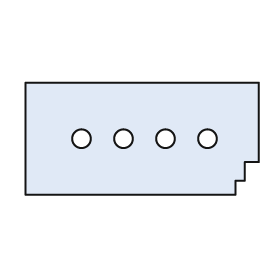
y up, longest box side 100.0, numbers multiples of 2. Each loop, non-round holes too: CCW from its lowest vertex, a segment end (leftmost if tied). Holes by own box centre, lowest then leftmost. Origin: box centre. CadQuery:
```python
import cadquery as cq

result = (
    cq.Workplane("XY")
    .moveTo(-50.0, -24.0)
    .lineTo(40.0, -24.0)
    .lineTo(40.0, -18.0)
    .lineTo(44.0, -18.0)
    .lineTo(44.0, -10.0)
    .lineTo(50.0, -10.0)
    .lineTo(50.0, 24.0)
    .lineTo(-50.0, 24.0)
    .close()
    .moveTo(-26.0, 0.0)
    .circle(4.0)
    .moveTo(-8.0, 0.0)
    .circle(4.0)
    .moveTo(10.0, 0.0)
    .circle(4.0)
    .moveTo(28.0, 0.0)
    .circle(4.0)
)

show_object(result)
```